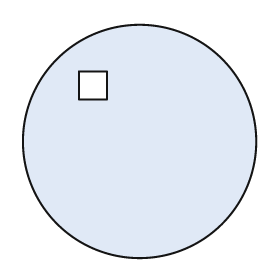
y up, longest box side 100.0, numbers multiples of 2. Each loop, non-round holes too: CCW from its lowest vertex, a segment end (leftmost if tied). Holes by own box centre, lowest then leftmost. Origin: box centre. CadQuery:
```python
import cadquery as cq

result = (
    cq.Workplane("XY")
    .moveTo(0.0, 0.0)
    .circle(50.0)
    .moveTo(-26.0, 18.0)
    .lineTo(-14.0, 18.0)
    .lineTo(-14.0, 30.0)
    .lineTo(-26.0, 30.0)
    .close()
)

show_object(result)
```